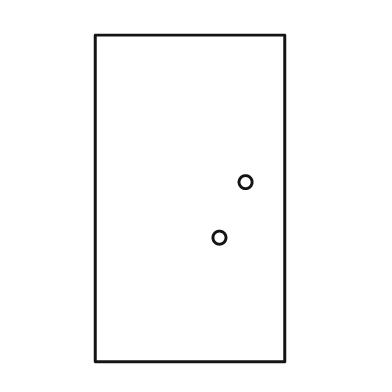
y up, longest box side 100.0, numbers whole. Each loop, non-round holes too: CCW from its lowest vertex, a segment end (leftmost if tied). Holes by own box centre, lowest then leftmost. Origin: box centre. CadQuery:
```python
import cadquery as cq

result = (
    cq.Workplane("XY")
    .moveTo(-29.0, -50.0)
    .lineTo(29.0, -50.0)
    .lineTo(29.0, 50.0)
    .lineTo(-29.0, 50.0)
    .close()
    .moveTo(9.0, -12.0)
    .circle(2.0)
    .moveTo(17.0, 5.0)
    .circle(2.0)
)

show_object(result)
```